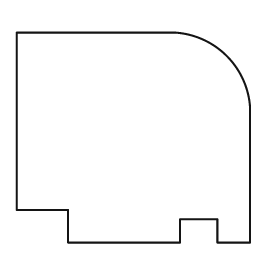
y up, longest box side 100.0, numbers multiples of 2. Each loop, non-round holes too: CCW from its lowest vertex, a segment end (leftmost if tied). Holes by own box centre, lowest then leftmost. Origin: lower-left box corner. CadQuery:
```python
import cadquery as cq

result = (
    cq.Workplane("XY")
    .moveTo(22.0, 0.0)
    .lineTo(70.0, 0.0)
    .lineTo(70.0, 10.0)
    .lineTo(86.0, 10.0)
    .lineTo(86.0, 0.0)
    .lineTo(100.0, 0.0)
    .lineTo(100.0, 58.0)
    .threePointArc((90.0, 80.0), (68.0, 90.0))
    .lineTo(0.0, 90.0)
    .lineTo(0.0, 14.0)
    .lineTo(22.0, 14.0)
    .close()
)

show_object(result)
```